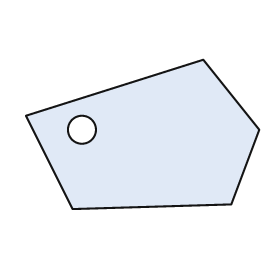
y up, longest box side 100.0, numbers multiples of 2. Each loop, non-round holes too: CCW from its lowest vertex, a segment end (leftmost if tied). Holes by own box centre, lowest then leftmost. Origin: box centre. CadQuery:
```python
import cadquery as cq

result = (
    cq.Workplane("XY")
    .moveTo(-30.0, -32.0)
    .lineTo(38.0, -30.0)
    .lineTo(50.0, 2.0)
    .lineTo(26.0, 32.0)
    .lineTo(-50.0, 8.0)
    .close()
    .moveTo(-26.0, 2.0)
    .circle(6.0)
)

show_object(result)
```